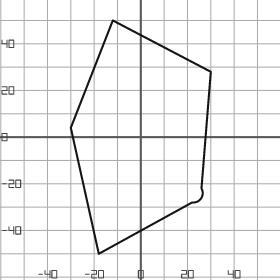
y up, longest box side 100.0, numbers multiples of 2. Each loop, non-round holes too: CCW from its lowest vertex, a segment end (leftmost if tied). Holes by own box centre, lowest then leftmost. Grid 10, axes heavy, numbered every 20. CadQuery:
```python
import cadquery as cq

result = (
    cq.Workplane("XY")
    .moveTo(-18.0, -50.0)
    .lineTo(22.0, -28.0)
    .threePointArc((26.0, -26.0), (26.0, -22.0))
    .lineTo(30.0, 28.0)
    .lineTo(-12.0, 50.0)
    .lineTo(-30.0, 4.0)
    .close()
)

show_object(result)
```